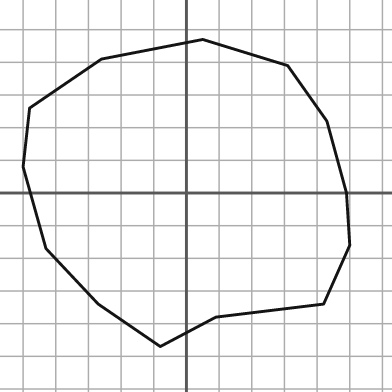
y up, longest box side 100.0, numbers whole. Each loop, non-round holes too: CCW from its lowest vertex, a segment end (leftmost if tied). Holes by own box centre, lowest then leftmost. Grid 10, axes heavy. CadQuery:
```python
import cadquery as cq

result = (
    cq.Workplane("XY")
    .moveTo(-8.0, -47.0)
    .lineTo(9.0, -38.0)
    .lineTo(42.0, -34.0)
    .lineTo(50.0, -16.0)
    .lineTo(49.0, 0.0)
    .lineTo(43.0, 22.0)
    .lineTo(31.0, 39.0)
    .lineTo(5.0, 47.0)
    .lineTo(-26.0, 41.0)
    .lineTo(-48.0, 26.0)
    .lineTo(-50.0, 8.0)
    .lineTo(-43.0, -17.0)
    .lineTo(-27.0, -34.0)
    .close()
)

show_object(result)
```